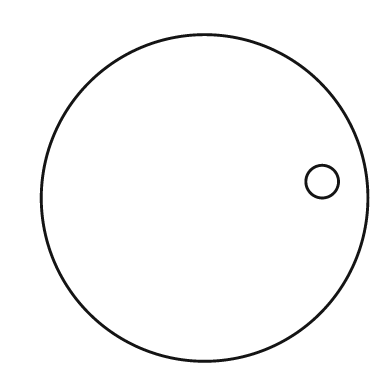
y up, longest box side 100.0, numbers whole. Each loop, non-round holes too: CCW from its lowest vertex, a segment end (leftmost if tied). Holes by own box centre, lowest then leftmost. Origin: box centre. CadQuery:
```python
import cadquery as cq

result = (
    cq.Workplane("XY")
    .moveTo(0.0, 0.0)
    .circle(50.0)
    .moveTo(36.0, 5.0)
    .circle(5.0)
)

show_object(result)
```